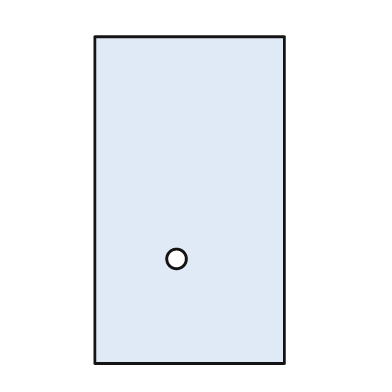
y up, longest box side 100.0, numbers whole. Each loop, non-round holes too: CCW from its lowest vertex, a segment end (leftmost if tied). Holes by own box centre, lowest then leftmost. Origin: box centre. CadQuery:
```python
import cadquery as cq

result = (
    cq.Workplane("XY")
    .moveTo(-29.0, -50.0)
    .lineTo(29.0, -50.0)
    .lineTo(29.0, 50.0)
    .lineTo(-29.0, 50.0)
    .close()
    .moveTo(-4.0, -18.0)
    .circle(3.0)
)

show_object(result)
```